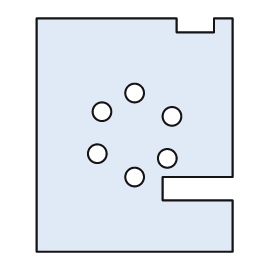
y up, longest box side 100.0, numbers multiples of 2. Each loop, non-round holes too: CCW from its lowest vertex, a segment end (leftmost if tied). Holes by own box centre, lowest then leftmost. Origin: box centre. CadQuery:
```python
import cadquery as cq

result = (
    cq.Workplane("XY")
    .moveTo(-42.0, -50.0)
    .lineTo(42.0, -50.0)
    .lineTo(42.0, -28.0)
    .lineTo(12.0, -28.0)
    .lineTo(12.0, -18.0)
    .lineTo(42.0, -18.0)
    .lineTo(42.0, 50.0)
    .lineTo(34.0, 50.0)
    .lineTo(34.0, 44.0)
    .lineTo(18.0, 44.0)
    .lineTo(18.0, 50.0)
    .lineTo(-42.0, 50.0)
    .close()
    .moveTo(0.0, -18.0)
    .circle(4.0)
    .moveTo(14.0, -10.0)
    .circle(4.0)
    .moveTo(-16.0, -8.0)
    .circle(4.0)
    .moveTo(16.0, 8.0)
    .circle(4.0)
    .moveTo(-14.0, 10.0)
    .circle(4.0)
    .moveTo(0.0, 18.0)
    .circle(4.0)
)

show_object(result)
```